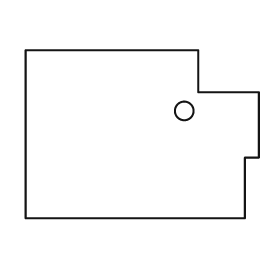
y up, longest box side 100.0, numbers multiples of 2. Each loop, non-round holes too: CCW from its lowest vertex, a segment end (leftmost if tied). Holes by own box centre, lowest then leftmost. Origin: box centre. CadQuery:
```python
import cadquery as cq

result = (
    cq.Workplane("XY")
    .moveTo(-50.0, -36.0)
    .lineTo(44.0, -36.0)
    .lineTo(44.0, -10.0)
    .lineTo(50.0, -10.0)
    .lineTo(50.0, 18.0)
    .lineTo(24.0, 18.0)
    .lineTo(24.0, 36.0)
    .lineTo(-50.0, 36.0)
    .close()
    .moveTo(18.0, 10.0)
    .circle(4.0)
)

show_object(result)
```